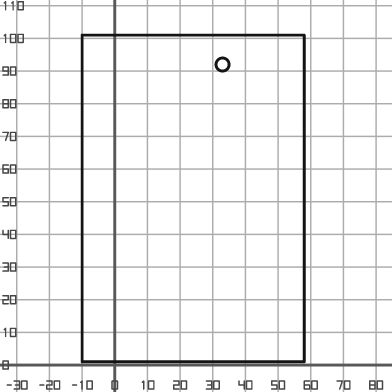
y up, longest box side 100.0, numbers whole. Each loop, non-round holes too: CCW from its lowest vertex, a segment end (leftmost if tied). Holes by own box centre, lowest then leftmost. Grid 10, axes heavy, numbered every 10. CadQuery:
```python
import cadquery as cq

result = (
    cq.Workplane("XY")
    .moveTo(-10.0, 1.0)
    .lineTo(58.0, 1.0)
    .lineTo(58.0, 101.0)
    .lineTo(-10.0, 101.0)
    .close()
    .moveTo(33.0, 92.0)
    .circle(2.0)
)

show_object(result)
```